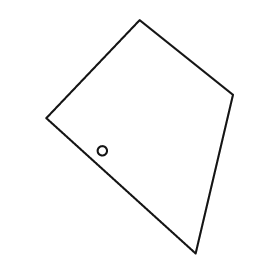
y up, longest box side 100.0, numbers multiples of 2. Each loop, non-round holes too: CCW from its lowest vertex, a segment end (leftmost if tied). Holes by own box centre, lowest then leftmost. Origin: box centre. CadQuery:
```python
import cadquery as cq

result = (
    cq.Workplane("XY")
    .moveTo(24.0, -50.0)
    .lineTo(40.0, 18.0)
    .lineTo(0.0, 50.0)
    .lineTo(-40.0, 8.0)
    .close()
    .moveTo(-16.0, -6.0)
    .circle(2.0)
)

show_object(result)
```